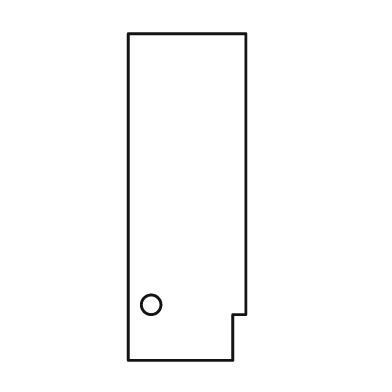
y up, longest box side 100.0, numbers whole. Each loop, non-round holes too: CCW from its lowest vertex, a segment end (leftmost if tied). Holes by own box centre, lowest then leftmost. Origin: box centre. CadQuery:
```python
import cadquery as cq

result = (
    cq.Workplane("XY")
    .moveTo(-18.0, -50.0)
    .lineTo(14.0, -50.0)
    .lineTo(14.0, -36.0)
    .lineTo(18.0, -36.0)
    .lineTo(18.0, 50.0)
    .lineTo(-18.0, 50.0)
    .close()
    .moveTo(-11.0, -33.0)
    .circle(3.0)
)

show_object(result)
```